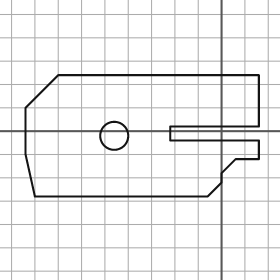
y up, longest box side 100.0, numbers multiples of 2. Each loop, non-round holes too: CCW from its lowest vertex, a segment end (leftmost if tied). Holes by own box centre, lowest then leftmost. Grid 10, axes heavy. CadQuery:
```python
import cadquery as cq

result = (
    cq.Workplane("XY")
    .moveTo(-80.0, -28.0)
    .lineTo(-6.0, -28.0)
    .lineTo(0.0, -22.0)
    .lineTo(0.0, -18.0)
    .lineTo(6.0, -12.0)
    .lineTo(16.0, -12.0)
    .lineTo(16.0, -4.0)
    .lineTo(-22.0, -4.0)
    .lineTo(-22.0, 2.0)
    .lineTo(16.0, 2.0)
    .lineTo(16.0, 24.0)
    .lineTo(-70.0, 24.0)
    .lineTo(-84.0, 10.0)
    .lineTo(-84.0, -10.0)
    .close()
    .moveTo(-46.0, -2.0)
    .circle(6.0)
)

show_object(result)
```